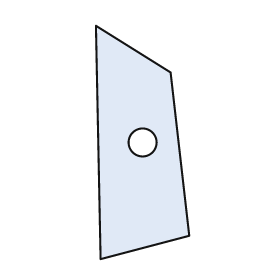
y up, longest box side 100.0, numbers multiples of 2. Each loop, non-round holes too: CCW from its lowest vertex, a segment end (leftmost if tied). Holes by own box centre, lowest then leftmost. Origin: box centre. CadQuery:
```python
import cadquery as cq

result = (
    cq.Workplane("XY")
    .moveTo(-18.0, -50.0)
    .lineTo(20.0, -40.0)
    .lineTo(12.0, 30.0)
    .lineTo(-20.0, 50.0)
    .close()
    .moveTo(0.0, 0.0)
    .circle(6.0)
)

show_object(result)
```